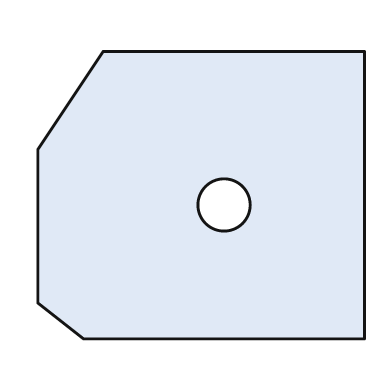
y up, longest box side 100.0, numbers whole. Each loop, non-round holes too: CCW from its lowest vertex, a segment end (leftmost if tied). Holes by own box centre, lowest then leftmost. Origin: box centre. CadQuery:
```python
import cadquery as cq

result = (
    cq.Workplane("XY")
    .moveTo(-36.0, -44.0)
    .lineTo(50.0, -44.0)
    .lineTo(50.0, 44.0)
    .lineTo(-30.0, 44.0)
    .lineTo(-50.0, 14.0)
    .lineTo(-50.0, -33.0)
    .close()
    .moveTo(7.0, -3.0)
    .circle(8.0)
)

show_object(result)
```